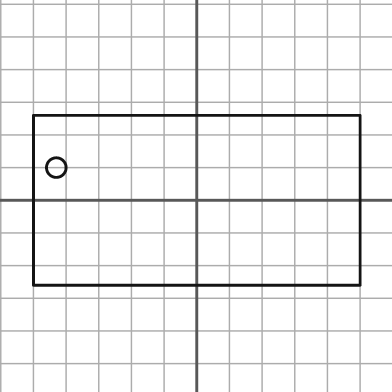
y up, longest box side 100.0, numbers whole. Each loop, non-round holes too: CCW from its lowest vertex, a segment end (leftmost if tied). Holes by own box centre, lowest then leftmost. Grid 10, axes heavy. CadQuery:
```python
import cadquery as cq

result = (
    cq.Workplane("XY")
    .moveTo(-50.0, -26.0)
    .lineTo(50.0, -26.0)
    .lineTo(50.0, 26.0)
    .lineTo(-50.0, 26.0)
    .close()
    .moveTo(-43.0, 10.0)
    .circle(3.0)
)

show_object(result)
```